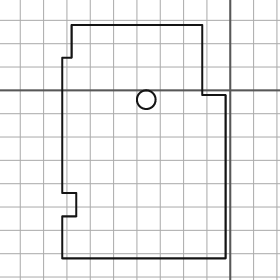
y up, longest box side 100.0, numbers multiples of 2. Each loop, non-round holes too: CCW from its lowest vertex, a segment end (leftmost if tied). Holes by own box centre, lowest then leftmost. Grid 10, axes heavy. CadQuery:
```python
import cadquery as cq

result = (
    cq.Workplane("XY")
    .moveTo(-72.0, -72.0)
    .lineTo(-2.0, -72.0)
    .lineTo(-2.0, -2.0)
    .lineTo(-12.0, -2.0)
    .lineTo(-12.0, 28.0)
    .lineTo(-68.0, 28.0)
    .lineTo(-68.0, 14.0)
    .lineTo(-72.0, 14.0)
    .lineTo(-72.0, -44.0)
    .lineTo(-66.0, -44.0)
    .lineTo(-66.0, -54.0)
    .lineTo(-72.0, -54.0)
    .close()
    .moveTo(-36.0, -4.0)
    .circle(4.0)
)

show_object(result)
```